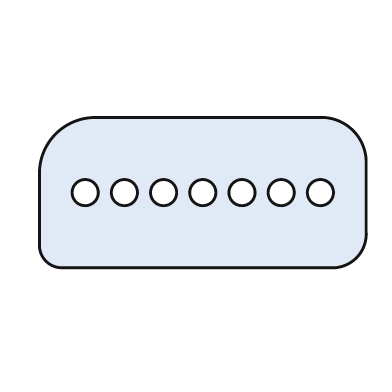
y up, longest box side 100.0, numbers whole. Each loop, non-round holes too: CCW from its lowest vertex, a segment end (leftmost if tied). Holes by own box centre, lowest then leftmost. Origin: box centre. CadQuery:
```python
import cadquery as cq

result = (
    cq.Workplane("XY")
    .moveTo(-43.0, -23.0)
    .lineTo(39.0, -23.0)
    .threePointArc((47.0, -20.0), (50.0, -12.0))
    .lineTo(50.0, 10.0)
    .threePointArc((46.0, 19.0), (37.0, 23.0))
    .lineTo(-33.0, 23.0)
    .threePointArc((-45.0, 18.0), (-50.0, 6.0))
    .lineTo(-50.0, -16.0)
    .threePointArc((-48.0, -21.0), (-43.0, -23.0))
    .close()
    .moveTo(-36.0, 0.0)
    .circle(4.0)
    .moveTo(-24.0, 0.0)
    .circle(4.0)
    .moveTo(-12.0, 0.0)
    .circle(4.0)
    .moveTo(0.0, 0.0)
    .circle(4.0)
    .moveTo(12.0, 0.0)
    .circle(4.0)
    .moveTo(24.0, 0.0)
    .circle(4.0)
    .moveTo(36.0, 0.0)
    .circle(4.0)
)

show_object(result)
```